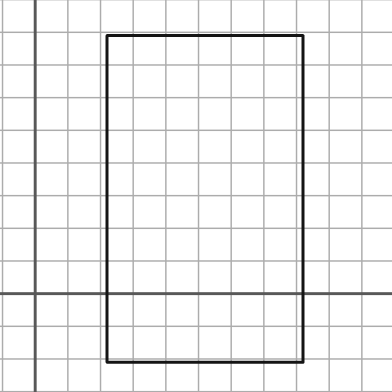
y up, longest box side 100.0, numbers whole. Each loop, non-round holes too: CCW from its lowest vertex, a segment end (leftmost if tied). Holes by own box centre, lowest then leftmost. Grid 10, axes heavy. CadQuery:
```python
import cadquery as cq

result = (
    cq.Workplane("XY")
    .moveTo(22.0, -21.0)
    .lineTo(82.0, -21.0)
    .lineTo(82.0, 79.0)
    .lineTo(22.0, 79.0)
    .close()
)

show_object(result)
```